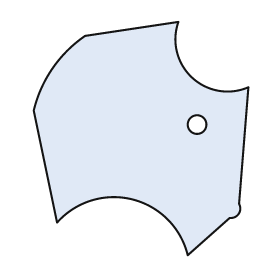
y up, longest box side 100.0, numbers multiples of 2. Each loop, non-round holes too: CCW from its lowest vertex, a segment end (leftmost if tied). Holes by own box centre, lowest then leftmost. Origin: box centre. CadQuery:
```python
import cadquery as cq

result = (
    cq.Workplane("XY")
    .moveTo(20.0, -50.0)
    .lineTo(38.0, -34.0)
    .threePointArc((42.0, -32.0), (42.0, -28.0))
    .lineTo(46.0, 22.0)
    .threePointArc((22.0, 26.0), (16.0, 50.0))
    .lineTo(-24.0, 44.0)
    .threePointArc((-38.0, 30.0), (-46.0, 12.0))
    .lineTo(-36.0, -36.0)
    .threePointArc((-4.0, -26.0), (20.0, -50.0))
    .close()
    .moveTo(24.0, 6.0)
    .circle(4.0)
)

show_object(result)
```